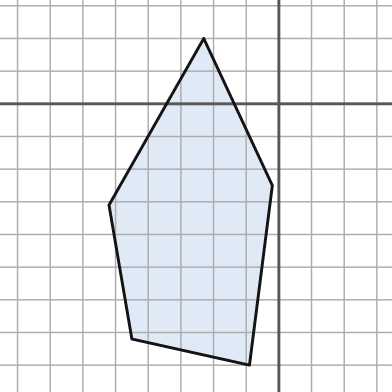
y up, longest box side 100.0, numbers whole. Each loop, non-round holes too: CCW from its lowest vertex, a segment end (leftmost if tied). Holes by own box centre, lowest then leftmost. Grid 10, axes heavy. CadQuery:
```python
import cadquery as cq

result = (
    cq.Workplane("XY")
    .moveTo(-9.0, -80.0)
    .lineTo(-2.0, -25.0)
    .lineTo(-23.0, 20.0)
    .lineTo(-52.0, -31.0)
    .lineTo(-45.0, -72.0)
    .close()
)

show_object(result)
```